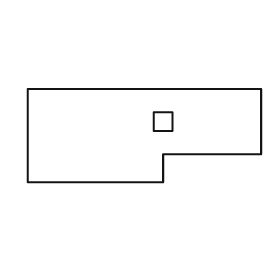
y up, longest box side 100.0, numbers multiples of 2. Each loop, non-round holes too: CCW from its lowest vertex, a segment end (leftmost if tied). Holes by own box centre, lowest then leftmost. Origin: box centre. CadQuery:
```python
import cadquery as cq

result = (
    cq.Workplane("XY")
    .moveTo(-50.0, -20.0)
    .lineTo(8.0, -20.0)
    .lineTo(8.0, -8.0)
    .lineTo(50.0, -8.0)
    .lineTo(50.0, 20.0)
    .lineTo(-50.0, 20.0)
    .close()
    .moveTo(4.0, 2.0)
    .lineTo(12.0, 2.0)
    .lineTo(12.0, 10.0)
    .lineTo(4.0, 10.0)
    .close()
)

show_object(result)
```